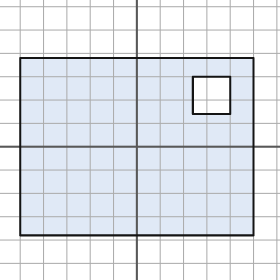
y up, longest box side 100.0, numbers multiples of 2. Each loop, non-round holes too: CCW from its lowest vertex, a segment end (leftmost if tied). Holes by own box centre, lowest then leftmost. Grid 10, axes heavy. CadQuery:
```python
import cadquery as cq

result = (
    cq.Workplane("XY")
    .moveTo(-50.0, -38.0)
    .lineTo(50.0, -38.0)
    .lineTo(50.0, 38.0)
    .lineTo(-50.0, 38.0)
    .close()
    .moveTo(24.0, 14.0)
    .lineTo(40.0, 14.0)
    .lineTo(40.0, 30.0)
    .lineTo(24.0, 30.0)
    .close()
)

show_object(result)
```